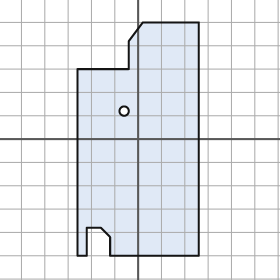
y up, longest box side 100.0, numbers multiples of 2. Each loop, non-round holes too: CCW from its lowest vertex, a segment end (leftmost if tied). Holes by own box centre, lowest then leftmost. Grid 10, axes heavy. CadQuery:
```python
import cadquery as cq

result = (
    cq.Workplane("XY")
    .moveTo(-26.0, -50.0)
    .lineTo(-22.0, -50.0)
    .lineTo(-22.0, -38.0)
    .lineTo(-16.0, -38.0)
    .lineTo(-12.0, -42.0)
    .lineTo(-12.0, -50.0)
    .lineTo(26.0, -50.0)
    .lineTo(26.0, 50.0)
    .lineTo(2.0, 50.0)
    .lineTo(-4.0, 42.0)
    .lineTo(-4.0, 30.0)
    .lineTo(-26.0, 30.0)
    .close()
    .moveTo(-6.0, 12.0)
    .circle(2.0)
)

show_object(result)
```